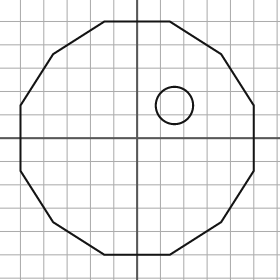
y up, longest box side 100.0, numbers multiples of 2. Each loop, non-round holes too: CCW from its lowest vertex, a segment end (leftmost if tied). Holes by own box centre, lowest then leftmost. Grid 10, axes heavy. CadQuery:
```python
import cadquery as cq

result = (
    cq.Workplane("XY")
    .moveTo(-14.0, -50.0)
    .lineTo(14.0, -50.0)
    .lineTo(36.0, -36.0)
    .lineTo(50.0, -14.0)
    .lineTo(50.0, 14.0)
    .lineTo(36.0, 36.0)
    .lineTo(14.0, 50.0)
    .lineTo(-14.0, 50.0)
    .lineTo(-36.0, 36.0)
    .lineTo(-50.0, 14.0)
    .lineTo(-50.0, -14.0)
    .lineTo(-36.0, -36.0)
    .close()
    .moveTo(16.0, 14.0)
    .circle(8.0)
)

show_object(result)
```